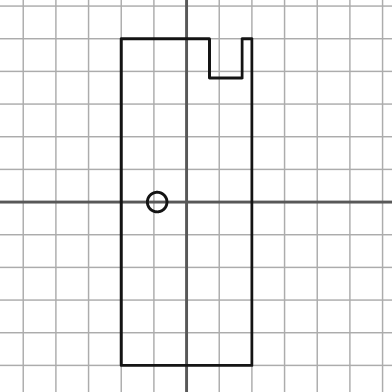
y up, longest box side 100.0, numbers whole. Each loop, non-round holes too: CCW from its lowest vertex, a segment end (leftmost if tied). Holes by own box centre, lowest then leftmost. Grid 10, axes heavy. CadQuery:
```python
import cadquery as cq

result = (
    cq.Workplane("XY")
    .moveTo(-20.0, -50.0)
    .lineTo(20.0, -50.0)
    .lineTo(20.0, 50.0)
    .lineTo(17.0, 50.0)
    .lineTo(17.0, 38.0)
    .lineTo(7.0, 38.0)
    .lineTo(7.0, 50.0)
    .lineTo(-20.0, 50.0)
    .close()
    .moveTo(-9.0, 0.0)
    .circle(3.0)
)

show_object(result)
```